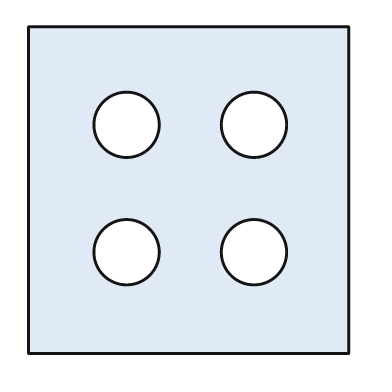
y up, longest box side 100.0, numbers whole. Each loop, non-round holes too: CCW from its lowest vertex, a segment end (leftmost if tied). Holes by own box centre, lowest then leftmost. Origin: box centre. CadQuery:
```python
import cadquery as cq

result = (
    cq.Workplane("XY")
    .moveTo(-49.0, -50.0)
    .lineTo(49.0, -50.0)
    .lineTo(49.0, 50.0)
    .lineTo(-49.0, 50.0)
    .close()
    .moveTo(-19.0, -19.0)
    .circle(10.0)
    .moveTo(20.0, -19.0)
    .circle(10.0)
    .moveTo(-19.0, 20.0)
    .circle(10.0)
    .moveTo(20.0, 20.0)
    .circle(10.0)
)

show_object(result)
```